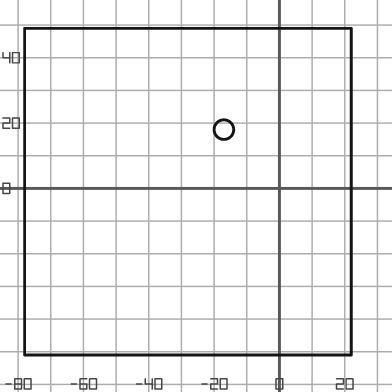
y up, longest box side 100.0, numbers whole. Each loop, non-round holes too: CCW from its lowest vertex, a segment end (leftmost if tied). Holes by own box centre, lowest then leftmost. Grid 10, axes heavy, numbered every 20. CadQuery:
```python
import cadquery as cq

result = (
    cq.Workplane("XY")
    .moveTo(-78.0, -51.0)
    .lineTo(22.0, -51.0)
    .lineTo(22.0, 49.0)
    .lineTo(-78.0, 49.0)
    .close()
    .moveTo(-17.0, 18.0)
    .circle(3.0)
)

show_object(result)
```